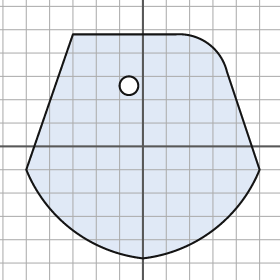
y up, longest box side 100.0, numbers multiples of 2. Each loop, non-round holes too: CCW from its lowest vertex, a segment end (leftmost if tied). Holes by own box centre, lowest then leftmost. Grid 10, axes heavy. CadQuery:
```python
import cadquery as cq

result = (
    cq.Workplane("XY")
    .moveTo(0.0, -48.0)
    .threePointArc((30.0, -36.0), (50.0, -10.0))
    .lineTo(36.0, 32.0)
    .threePointArc((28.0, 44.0), (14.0, 48.0))
    .lineTo(-30.0, 48.0)
    .lineTo(-50.0, -10.0)
    .threePointArc((-30.0, -36.0), (0.0, -48.0))
    .close()
    .moveTo(-6.0, 26.0)
    .circle(4.0)
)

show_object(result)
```